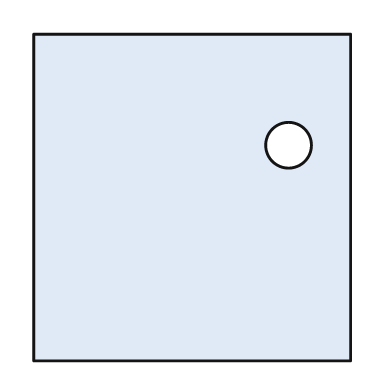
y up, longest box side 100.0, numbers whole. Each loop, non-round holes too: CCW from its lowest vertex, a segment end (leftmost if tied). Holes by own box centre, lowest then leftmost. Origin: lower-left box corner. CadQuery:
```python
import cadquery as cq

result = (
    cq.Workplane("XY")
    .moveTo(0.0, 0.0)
    .lineTo(97.0, 0.0)
    .lineTo(97.0, 100.0)
    .lineTo(0.0, 100.0)
    .close()
    .moveTo(78.0, 66.0)
    .circle(7.0)
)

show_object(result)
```